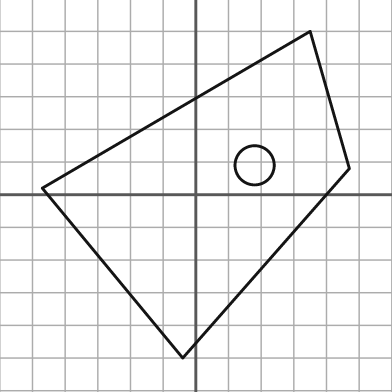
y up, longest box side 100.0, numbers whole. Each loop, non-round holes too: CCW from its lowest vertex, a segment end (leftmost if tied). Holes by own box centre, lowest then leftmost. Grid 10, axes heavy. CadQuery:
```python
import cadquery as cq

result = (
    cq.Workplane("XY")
    .moveTo(-4.0, -50.0)
    .lineTo(47.0, 8.0)
    .lineTo(35.0, 50.0)
    .lineTo(-47.0, 2.0)
    .close()
    .moveTo(18.0, 9.0)
    .circle(6.0)
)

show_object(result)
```